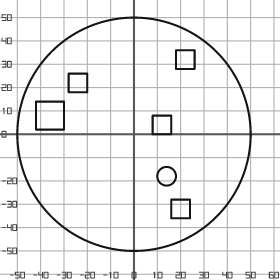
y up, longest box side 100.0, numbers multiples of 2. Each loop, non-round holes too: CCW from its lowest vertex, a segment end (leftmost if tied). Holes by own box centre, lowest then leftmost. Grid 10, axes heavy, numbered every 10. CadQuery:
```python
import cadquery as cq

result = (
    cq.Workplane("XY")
    .moveTo(0.0, 0.0)
    .circle(50.0)
    .moveTo(16.0, -36.0)
    .lineTo(24.0, -36.0)
    .lineTo(24.0, -28.0)
    .lineTo(16.0, -28.0)
    .close()
    .moveTo(14.0, -18.0)
    .circle(4.0)
    .moveTo(8.0, 0.0)
    .lineTo(16.0, 0.0)
    .lineTo(16.0, 8.0)
    .lineTo(8.0, 8.0)
    .close()
    .moveTo(-42.0, 2.0)
    .lineTo(-30.0, 2.0)
    .lineTo(-30.0, 14.0)
    .lineTo(-42.0, 14.0)
    .close()
    .moveTo(-28.0, 18.0)
    .lineTo(-20.0, 18.0)
    .lineTo(-20.0, 26.0)
    .lineTo(-28.0, 26.0)
    .close()
    .moveTo(18.0, 28.0)
    .lineTo(26.0, 28.0)
    .lineTo(26.0, 36.0)
    .lineTo(18.0, 36.0)
    .close()
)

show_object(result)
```